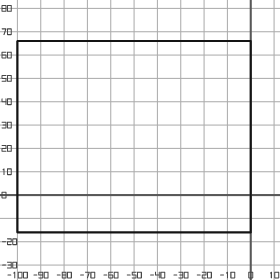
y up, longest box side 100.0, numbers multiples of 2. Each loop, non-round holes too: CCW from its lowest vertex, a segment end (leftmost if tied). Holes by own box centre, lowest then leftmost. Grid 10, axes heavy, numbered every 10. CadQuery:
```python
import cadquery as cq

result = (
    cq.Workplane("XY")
    .moveTo(-100.0, -16.0)
    .lineTo(0.0, -16.0)
    .lineTo(0.0, 66.0)
    .lineTo(-100.0, 66.0)
    .close()
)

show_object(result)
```